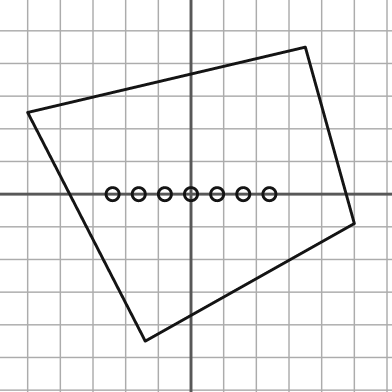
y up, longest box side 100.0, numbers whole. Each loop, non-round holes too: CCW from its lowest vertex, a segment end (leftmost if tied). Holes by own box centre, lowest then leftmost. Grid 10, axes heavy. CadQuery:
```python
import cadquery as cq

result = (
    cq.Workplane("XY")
    .moveTo(-14.0, -45.0)
    .lineTo(50.0, -9.0)
    .lineTo(35.0, 45.0)
    .lineTo(-50.0, 25.0)
    .close()
    .moveTo(-24.0, 0.0)
    .circle(2.0)
    .moveTo(-16.0, 0.0)
    .circle(2.0)
    .moveTo(-8.0, 0.0)
    .circle(2.0)
    .moveTo(0.0, 0.0)
    .circle(2.0)
    .moveTo(8.0, 0.0)
    .circle(2.0)
    .moveTo(16.0, 0.0)
    .circle(2.0)
    .moveTo(24.0, 0.0)
    .circle(2.0)
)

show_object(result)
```